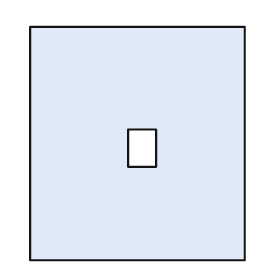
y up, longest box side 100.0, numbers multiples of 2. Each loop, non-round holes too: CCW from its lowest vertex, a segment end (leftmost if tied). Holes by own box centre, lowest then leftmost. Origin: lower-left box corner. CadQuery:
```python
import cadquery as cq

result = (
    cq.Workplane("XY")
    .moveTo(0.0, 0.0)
    .lineTo(92.0, 0.0)
    .lineTo(92.0, 100.0)
    .lineTo(0.0, 100.0)
    .close()
    .moveTo(42.0, 40.0)
    .lineTo(54.0, 40.0)
    .lineTo(54.0, 56.0)
    .lineTo(42.0, 56.0)
    .close()
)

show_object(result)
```